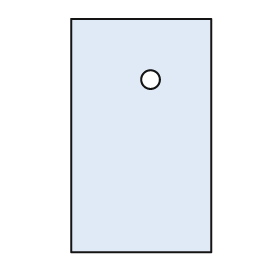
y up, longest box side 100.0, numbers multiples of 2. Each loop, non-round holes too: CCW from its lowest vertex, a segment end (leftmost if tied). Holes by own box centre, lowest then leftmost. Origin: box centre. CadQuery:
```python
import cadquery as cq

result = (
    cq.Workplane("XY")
    .moveTo(-30.0, -50.0)
    .lineTo(30.0, -50.0)
    .lineTo(30.0, 50.0)
    .lineTo(-30.0, 50.0)
    .close()
    .moveTo(4.0, 24.0)
    .circle(4.0)
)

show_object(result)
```